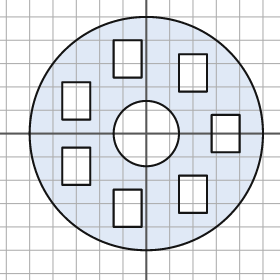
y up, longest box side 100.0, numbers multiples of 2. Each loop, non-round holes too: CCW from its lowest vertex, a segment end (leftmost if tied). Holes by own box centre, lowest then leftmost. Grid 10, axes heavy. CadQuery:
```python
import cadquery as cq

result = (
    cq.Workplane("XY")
    .moveTo(0.0, 0.0)
    .circle(50.0)
    .moveTo(-14.0, -40.0)
    .lineTo(-2.0, -40.0)
    .lineTo(-2.0, -24.0)
    .lineTo(-14.0, -24.0)
    .close()
    .moveTo(14.0, -34.0)
    .lineTo(26.0, -34.0)
    .lineTo(26.0, -18.0)
    .lineTo(14.0, -18.0)
    .close()
    .moveTo(-36.0, -22.0)
    .lineTo(-24.0, -22.0)
    .lineTo(-24.0, -6.0)
    .lineTo(-36.0, -6.0)
    .close()
    .moveTo(0.0, 0.0)
    .circle(14.0)
    .moveTo(28.0, -8.0)
    .lineTo(40.0, -8.0)
    .lineTo(40.0, 8.0)
    .lineTo(28.0, 8.0)
    .close()
    .moveTo(-36.0, 6.0)
    .lineTo(-24.0, 6.0)
    .lineTo(-24.0, 22.0)
    .lineTo(-36.0, 22.0)
    .close()
    .moveTo(14.0, 18.0)
    .lineTo(26.0, 18.0)
    .lineTo(26.0, 34.0)
    .lineTo(14.0, 34.0)
    .close()
    .moveTo(-14.0, 24.0)
    .lineTo(-2.0, 24.0)
    .lineTo(-2.0, 40.0)
    .lineTo(-14.0, 40.0)
    .close()
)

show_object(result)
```